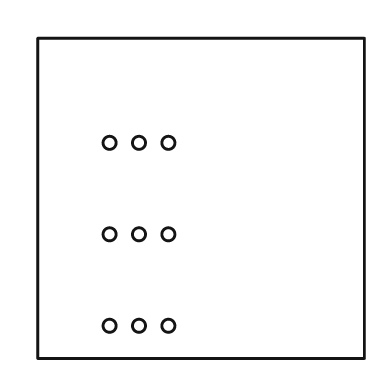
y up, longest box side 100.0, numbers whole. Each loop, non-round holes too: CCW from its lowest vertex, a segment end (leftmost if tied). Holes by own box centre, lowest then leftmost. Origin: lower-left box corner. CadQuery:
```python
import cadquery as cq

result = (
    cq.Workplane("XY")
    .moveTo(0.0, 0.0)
    .lineTo(100.0, 0.0)
    .lineTo(100.0, 98.0)
    .lineTo(0.0, 98.0)
    .close()
    .moveTo(22.0, 10.0)
    .circle(2.0)
    .moveTo(31.0, 10.0)
    .circle(2.0)
    .moveTo(40.0, 10.0)
    .circle(2.0)
    .moveTo(22.0, 38.0)
    .circle(2.0)
    .moveTo(31.0, 38.0)
    .circle(2.0)
    .moveTo(40.0, 38.0)
    .circle(2.0)
    .moveTo(22.0, 66.0)
    .circle(2.0)
    .moveTo(31.0, 66.0)
    .circle(2.0)
    .moveTo(40.0, 66.0)
    .circle(2.0)
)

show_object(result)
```